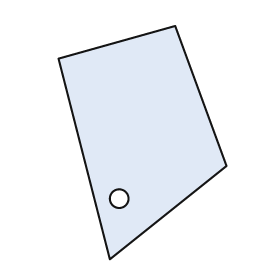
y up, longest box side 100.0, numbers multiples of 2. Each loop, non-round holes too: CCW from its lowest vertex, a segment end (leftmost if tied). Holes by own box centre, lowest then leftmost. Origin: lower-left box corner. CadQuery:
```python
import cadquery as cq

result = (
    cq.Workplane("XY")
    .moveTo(22.0, 0.0)
    .lineTo(72.0, 40.0)
    .lineTo(50.0, 100.0)
    .lineTo(0.0, 86.0)
    .close()
    .moveTo(26.0, 26.0)
    .circle(4.0)
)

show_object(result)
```